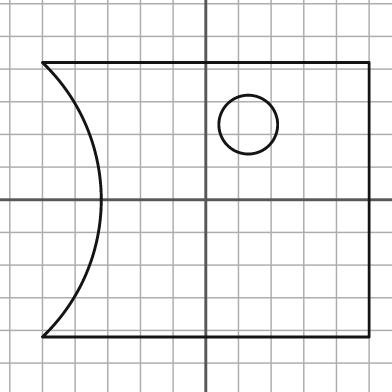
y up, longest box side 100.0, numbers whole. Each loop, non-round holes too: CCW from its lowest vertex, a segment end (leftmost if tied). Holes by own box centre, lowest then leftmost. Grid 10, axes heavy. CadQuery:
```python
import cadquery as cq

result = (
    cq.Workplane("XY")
    .moveTo(-50.0, -42.0)
    .lineTo(50.0, -42.0)
    .lineTo(50.0, 42.0)
    .lineTo(-50.0, 42.0)
    .threePointArc((-32.0, 0.0), (-50.0, -42.0))
    .close()
    .moveTo(13.0, 23.0)
    .circle(9.0)
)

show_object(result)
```